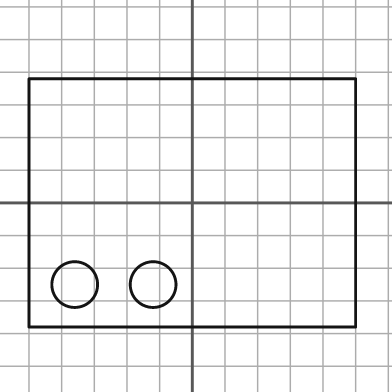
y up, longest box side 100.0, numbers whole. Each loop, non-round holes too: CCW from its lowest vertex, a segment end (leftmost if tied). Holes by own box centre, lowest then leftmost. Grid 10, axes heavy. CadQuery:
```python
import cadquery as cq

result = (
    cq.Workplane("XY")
    .moveTo(-50.0, -38.0)
    .lineTo(50.0, -38.0)
    .lineTo(50.0, 38.0)
    .lineTo(-50.0, 38.0)
    .close()
    .moveTo(-36.0, -25.0)
    .circle(7.0)
    .moveTo(-12.0, -25.0)
    .circle(7.0)
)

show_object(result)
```